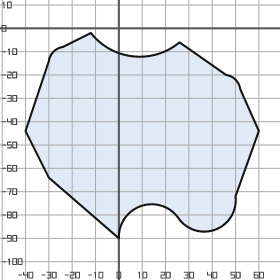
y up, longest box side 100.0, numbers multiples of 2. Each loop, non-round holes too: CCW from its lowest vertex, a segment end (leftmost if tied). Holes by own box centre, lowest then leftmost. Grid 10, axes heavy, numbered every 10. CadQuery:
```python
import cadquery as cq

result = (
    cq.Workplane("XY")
    .moveTo(0.0, -90.0)
    .threePointArc((10.0, -76.0), (26.0, -82.0))
    .threePointArc((42.0, -86.0), (50.0, -72.0))
    .lineTo(60.0, -44.0)
    .lineTo(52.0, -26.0)
    .threePointArc((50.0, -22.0), (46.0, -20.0))
    .lineTo(26.0, -6.0)
    .threePointArc((6.0, -12.0), (-12.0, -2.0))
    .lineTo(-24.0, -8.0)
    .threePointArc((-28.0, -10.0), (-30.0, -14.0))
    .lineTo(-40.0, -44.0)
    .lineTo(-30.0, -64.0)
    .close()
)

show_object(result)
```